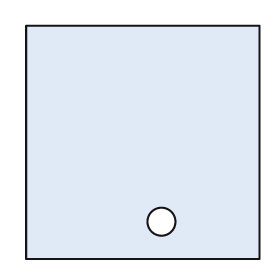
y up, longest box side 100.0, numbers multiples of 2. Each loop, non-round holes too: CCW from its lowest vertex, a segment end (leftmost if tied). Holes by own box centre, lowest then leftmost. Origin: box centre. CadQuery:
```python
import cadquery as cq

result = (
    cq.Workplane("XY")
    .moveTo(-50.0, -50.0)
    .lineTo(50.0, -50.0)
    .lineTo(50.0, 50.0)
    .lineTo(-50.0, 50.0)
    .close()
    .moveTo(8.0, -34.0)
    .circle(6.0)
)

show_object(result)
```